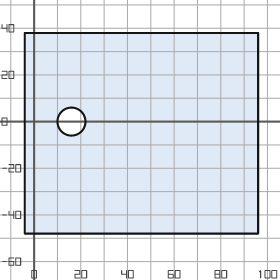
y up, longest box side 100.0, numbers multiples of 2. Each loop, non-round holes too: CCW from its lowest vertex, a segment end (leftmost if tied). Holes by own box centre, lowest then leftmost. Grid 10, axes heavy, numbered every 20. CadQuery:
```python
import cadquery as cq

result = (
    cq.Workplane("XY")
    .moveTo(-4.0, -48.0)
    .lineTo(96.0, -48.0)
    .lineTo(96.0, 38.0)
    .lineTo(-4.0, 38.0)
    .close()
    .moveTo(16.0, 0.0)
    .circle(6.0)
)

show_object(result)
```